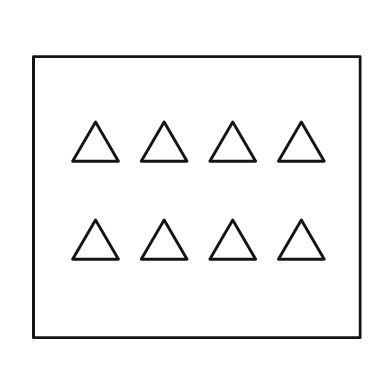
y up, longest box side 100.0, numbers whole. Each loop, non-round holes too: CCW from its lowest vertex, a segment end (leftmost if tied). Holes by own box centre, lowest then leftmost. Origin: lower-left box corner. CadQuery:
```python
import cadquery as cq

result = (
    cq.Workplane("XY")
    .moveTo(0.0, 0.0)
    .lineTo(100.0, 0.0)
    .lineTo(100.0, 86.0)
    .lineTo(0.0, 86.0)
    .close()
    .moveTo(12.0, 24.0)
    .lineTo(26.0, 24.0)
    .lineTo(19.0, 36.0)
    .close()
    .moveTo(33.0, 24.0)
    .lineTo(47.0, 24.0)
    .lineTo(40.0, 36.0)
    .close()
    .moveTo(54.0, 24.0)
    .lineTo(68.0, 24.0)
    .lineTo(61.0, 36.0)
    .close()
    .moveTo(75.0, 24.0)
    .lineTo(89.0, 24.0)
    .lineTo(82.0, 36.0)
    .close()
    .moveTo(12.0, 54.0)
    .lineTo(26.0, 54.0)
    .lineTo(19.0, 66.0)
    .close()
    .moveTo(33.0, 54.0)
    .lineTo(47.0, 54.0)
    .lineTo(40.0, 66.0)
    .close()
    .moveTo(54.0, 54.0)
    .lineTo(68.0, 54.0)
    .lineTo(61.0, 66.0)
    .close()
    .moveTo(75.0, 54.0)
    .lineTo(89.0, 54.0)
    .lineTo(82.0, 66.0)
    .close()
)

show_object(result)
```